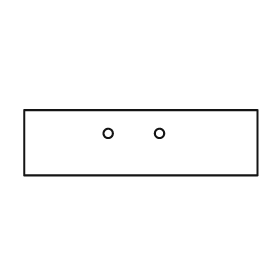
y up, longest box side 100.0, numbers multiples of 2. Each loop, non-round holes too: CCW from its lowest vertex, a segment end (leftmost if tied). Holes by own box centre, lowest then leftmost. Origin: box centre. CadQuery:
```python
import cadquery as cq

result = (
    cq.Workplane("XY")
    .moveTo(-50.0, -14.0)
    .lineTo(50.0, -14.0)
    .lineTo(50.0, 14.0)
    .lineTo(-50.0, 14.0)
    .close()
    .moveTo(-14.0, 4.0)
    .circle(2.0)
    .moveTo(8.0, 4.0)
    .circle(2.0)
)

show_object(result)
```